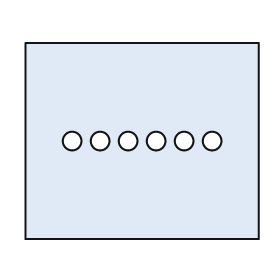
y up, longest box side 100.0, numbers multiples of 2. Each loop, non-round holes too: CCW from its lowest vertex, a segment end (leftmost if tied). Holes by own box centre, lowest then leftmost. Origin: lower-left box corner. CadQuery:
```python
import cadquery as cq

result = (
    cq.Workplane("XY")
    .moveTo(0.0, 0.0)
    .lineTo(100.0, 0.0)
    .lineTo(100.0, 84.0)
    .lineTo(0.0, 84.0)
    .close()
    .moveTo(20.0, 42.0)
    .circle(4.0)
    .moveTo(32.0, 42.0)
    .circle(4.0)
    .moveTo(44.0, 42.0)
    .circle(4.0)
    .moveTo(56.0, 42.0)
    .circle(4.0)
    .moveTo(68.0, 42.0)
    .circle(4.0)
    .moveTo(80.0, 42.0)
    .circle(4.0)
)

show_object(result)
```